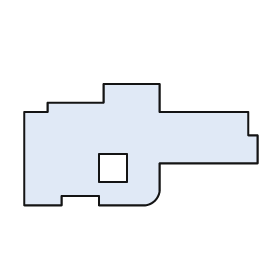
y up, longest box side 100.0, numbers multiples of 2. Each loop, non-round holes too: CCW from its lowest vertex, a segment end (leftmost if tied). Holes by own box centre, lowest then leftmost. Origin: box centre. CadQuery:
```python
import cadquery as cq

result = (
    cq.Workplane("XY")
    .moveTo(-50.0, -26.0)
    .lineTo(-34.0, -26.0)
    .lineTo(-34.0, -22.0)
    .lineTo(-18.0, -22.0)
    .lineTo(-18.0, -26.0)
    .lineTo(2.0, -26.0)
    .threePointArc((6.0, -24.0), (8.0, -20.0))
    .lineTo(8.0, -8.0)
    .lineTo(50.0, -8.0)
    .lineTo(50.0, 4.0)
    .lineTo(46.0, 4.0)
    .lineTo(46.0, 14.0)
    .lineTo(8.0, 14.0)
    .lineTo(8.0, 26.0)
    .lineTo(-16.0, 26.0)
    .lineTo(-16.0, 18.0)
    .lineTo(-40.0, 18.0)
    .lineTo(-40.0, 14.0)
    .lineTo(-50.0, 14.0)
    .close()
    .moveTo(-18.0, -16.0)
    .lineTo(-6.0, -16.0)
    .lineTo(-6.0, -4.0)
    .lineTo(-18.0, -4.0)
    .close()
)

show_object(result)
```